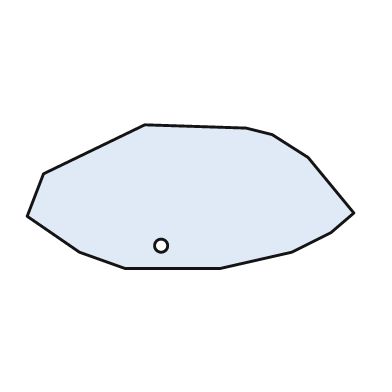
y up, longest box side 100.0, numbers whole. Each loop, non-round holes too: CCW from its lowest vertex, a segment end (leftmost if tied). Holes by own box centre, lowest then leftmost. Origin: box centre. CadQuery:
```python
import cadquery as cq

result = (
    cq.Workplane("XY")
    .moveTo(-20.0, -22.0)
    .lineTo(9.0, -22.0)
    .lineTo(31.0, -17.0)
    .lineTo(43.0, -11.0)
    .lineTo(50.0, -5.0)
    .lineTo(36.0, 12.0)
    .lineTo(25.0, 19.0)
    .lineTo(17.0, 21.0)
    .lineTo(-14.0, 22.0)
    .lineTo(-45.0, 7.0)
    .lineTo(-50.0, -6.0)
    .lineTo(-34.0, -17.0)
    .close()
    .moveTo(-9.0, -15.0)
    .circle(2.0)
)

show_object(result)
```